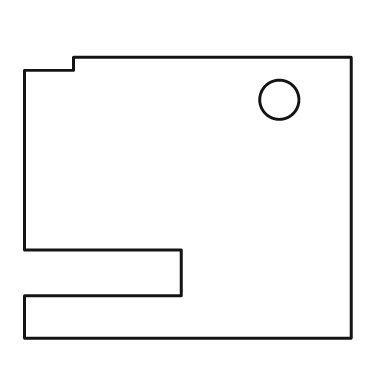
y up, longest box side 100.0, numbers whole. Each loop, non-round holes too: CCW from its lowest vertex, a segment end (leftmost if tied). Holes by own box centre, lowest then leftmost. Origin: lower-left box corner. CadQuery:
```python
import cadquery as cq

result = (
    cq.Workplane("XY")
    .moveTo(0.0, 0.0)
    .lineTo(100.0, 0.0)
    .lineTo(100.0, 86.0)
    .lineTo(15.0, 86.0)
    .lineTo(15.0, 82.0)
    .lineTo(0.0, 82.0)
    .lineTo(0.0, 27.0)
    .lineTo(48.0, 27.0)
    .lineTo(48.0, 13.0)
    .lineTo(0.0, 13.0)
    .close()
    .moveTo(78.0, 73.0)
    .circle(6.0)
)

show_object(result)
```